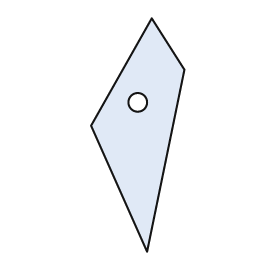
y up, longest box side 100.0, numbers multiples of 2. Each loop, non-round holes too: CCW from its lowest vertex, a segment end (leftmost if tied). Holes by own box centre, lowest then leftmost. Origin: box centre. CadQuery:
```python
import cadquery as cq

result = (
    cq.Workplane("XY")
    .moveTo(4.0, -50.0)
    .lineTo(20.0, 28.0)
    .lineTo(6.0, 50.0)
    .lineTo(-20.0, 4.0)
    .close()
    .moveTo(0.0, 14.0)
    .circle(4.0)
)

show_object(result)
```